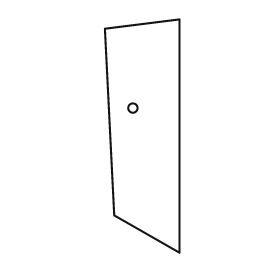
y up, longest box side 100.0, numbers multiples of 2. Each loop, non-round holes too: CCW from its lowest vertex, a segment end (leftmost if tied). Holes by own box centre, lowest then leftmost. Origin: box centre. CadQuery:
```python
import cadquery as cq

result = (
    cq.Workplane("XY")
    .moveTo(16.0, -50.0)
    .lineTo(16.0, 50.0)
    .lineTo(-16.0, 46.0)
    .lineTo(-12.0, -34.0)
    .close()
    .moveTo(-4.0, 12.0)
    .circle(2.0)
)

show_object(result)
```